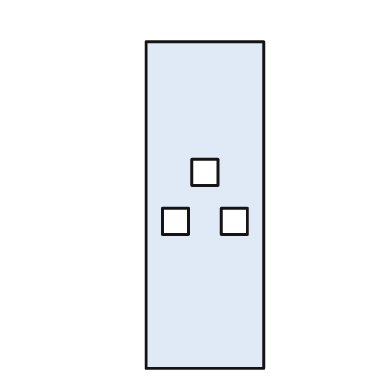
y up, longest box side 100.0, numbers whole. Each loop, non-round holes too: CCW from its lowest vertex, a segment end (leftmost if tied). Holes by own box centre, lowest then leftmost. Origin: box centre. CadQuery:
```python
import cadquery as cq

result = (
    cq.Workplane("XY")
    .moveTo(-18.0, -50.0)
    .lineTo(18.0, -50.0)
    .lineTo(18.0, 50.0)
    .lineTo(-18.0, 50.0)
    .close()
    .moveTo(-13.0, -9.0)
    .lineTo(-5.0, -9.0)
    .lineTo(-5.0, -1.0)
    .lineTo(-13.0, -1.0)
    .close()
    .moveTo(5.0, -9.0)
    .lineTo(13.0, -9.0)
    .lineTo(13.0, -1.0)
    .lineTo(5.0, -1.0)
    .close()
    .moveTo(-4.0, 6.0)
    .lineTo(4.0, 6.0)
    .lineTo(4.0, 14.0)
    .lineTo(-4.0, 14.0)
    .close()
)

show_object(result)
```